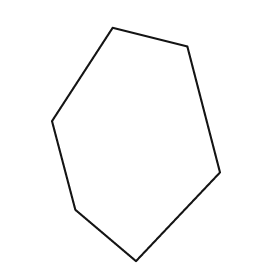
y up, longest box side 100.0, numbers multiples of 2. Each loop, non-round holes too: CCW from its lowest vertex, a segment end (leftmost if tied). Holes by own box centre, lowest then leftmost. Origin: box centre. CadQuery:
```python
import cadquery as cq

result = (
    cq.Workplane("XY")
    .moveTo(0.0, -50.0)
    .lineTo(36.0, -12.0)
    .lineTo(22.0, 42.0)
    .lineTo(-10.0, 50.0)
    .lineTo(-36.0, 10.0)
    .lineTo(-26.0, -28.0)
    .close()
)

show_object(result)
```